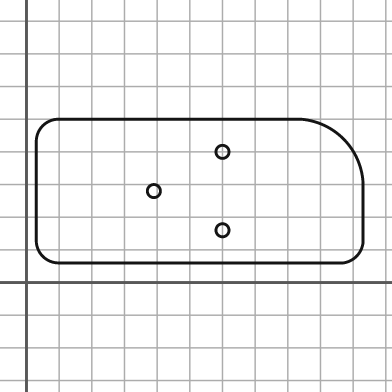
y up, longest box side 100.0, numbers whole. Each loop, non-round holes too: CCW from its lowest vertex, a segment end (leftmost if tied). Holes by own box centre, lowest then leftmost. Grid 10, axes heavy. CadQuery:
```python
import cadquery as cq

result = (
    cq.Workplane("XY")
    .moveTo(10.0, 6.0)
    .lineTo(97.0, 6.0)
    .threePointArc((101.0, 8.0), (103.0, 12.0))
    .lineTo(103.0, 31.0)
    .threePointArc((97.0, 44.0), (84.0, 50.0))
    .lineTo(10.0, 50.0)
    .threePointArc((5.0, 48.0), (3.0, 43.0))
    .lineTo(3.0, 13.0)
    .threePointArc((5.0, 8.0), (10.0, 6.0))
    .close()
    .moveTo(60.0, 16.0)
    .circle(2.0)
    .moveTo(39.0, 28.0)
    .circle(2.0)
    .moveTo(60.0, 40.0)
    .circle(2.0)
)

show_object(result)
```